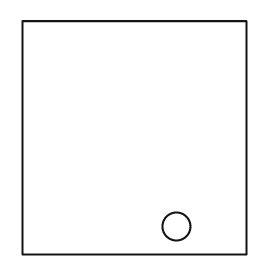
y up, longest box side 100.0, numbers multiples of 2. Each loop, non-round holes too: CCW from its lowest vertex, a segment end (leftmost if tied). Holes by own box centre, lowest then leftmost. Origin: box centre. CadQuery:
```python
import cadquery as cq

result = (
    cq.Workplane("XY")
    .moveTo(-48.0, -50.0)
    .lineTo(48.0, -50.0)
    .lineTo(48.0, 50.0)
    .lineTo(-48.0, 50.0)
    .close()
    .moveTo(18.0, -38.0)
    .circle(6.0)
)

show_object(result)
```